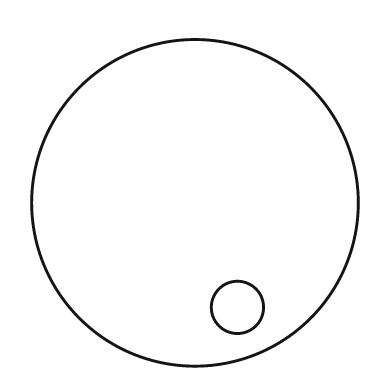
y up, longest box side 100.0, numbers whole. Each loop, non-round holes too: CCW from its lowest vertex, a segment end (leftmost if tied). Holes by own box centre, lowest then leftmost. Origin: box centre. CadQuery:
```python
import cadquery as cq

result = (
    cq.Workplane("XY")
    .moveTo(0.0, 0.0)
    .circle(50.0)
    .moveTo(13.0, -32.0)
    .circle(8.0)
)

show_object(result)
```